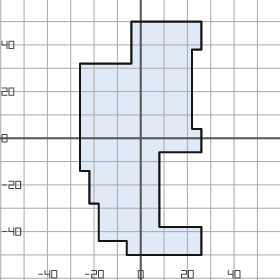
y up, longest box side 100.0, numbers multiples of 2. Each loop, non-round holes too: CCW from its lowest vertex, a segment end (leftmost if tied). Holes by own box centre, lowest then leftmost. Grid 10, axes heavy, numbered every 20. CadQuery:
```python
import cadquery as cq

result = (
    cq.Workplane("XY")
    .moveTo(-6.0, -50.0)
    .lineTo(26.0, -50.0)
    .lineTo(26.0, -38.0)
    .lineTo(8.0, -38.0)
    .lineTo(8.0, -6.0)
    .lineTo(26.0, -6.0)
    .lineTo(26.0, 4.0)
    .lineTo(22.0, 4.0)
    .lineTo(22.0, 38.0)
    .lineTo(26.0, 38.0)
    .lineTo(26.0, 50.0)
    .lineTo(-4.0, 50.0)
    .lineTo(-4.0, 32.0)
    .lineTo(-26.0, 32.0)
    .lineTo(-26.0, -14.0)
    .lineTo(-22.0, -14.0)
    .lineTo(-22.0, -28.0)
    .lineTo(-18.0, -28.0)
    .lineTo(-18.0, -44.0)
    .lineTo(-6.0, -44.0)
    .close()
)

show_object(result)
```